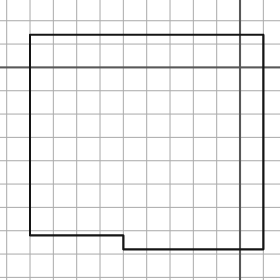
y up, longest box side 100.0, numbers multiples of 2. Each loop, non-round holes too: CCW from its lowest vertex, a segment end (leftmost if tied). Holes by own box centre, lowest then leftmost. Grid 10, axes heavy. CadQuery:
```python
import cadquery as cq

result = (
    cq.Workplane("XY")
    .moveTo(-50.0, -78.0)
    .lineTo(10.0, -78.0)
    .lineTo(10.0, 14.0)
    .lineTo(-90.0, 14.0)
    .lineTo(-90.0, -72.0)
    .lineTo(-50.0, -72.0)
    .close()
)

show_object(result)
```